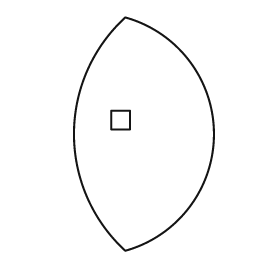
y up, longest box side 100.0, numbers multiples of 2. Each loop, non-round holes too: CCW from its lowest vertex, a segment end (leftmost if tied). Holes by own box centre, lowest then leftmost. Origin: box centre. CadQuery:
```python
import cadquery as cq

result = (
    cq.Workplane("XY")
    .moveTo(-8.0, -50.0)
    .threePointArc((30.0, 0.0), (-8.0, 50.0))
    .threePointArc((-30.0, 0.0), (-8.0, -50.0))
    .close()
    .moveTo(-14.0, 2.0)
    .lineTo(-6.0, 2.0)
    .lineTo(-6.0, 10.0)
    .lineTo(-14.0, 10.0)
    .close()
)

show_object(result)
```